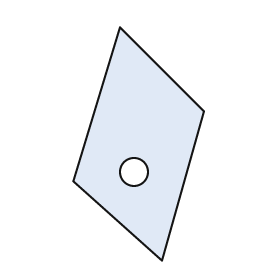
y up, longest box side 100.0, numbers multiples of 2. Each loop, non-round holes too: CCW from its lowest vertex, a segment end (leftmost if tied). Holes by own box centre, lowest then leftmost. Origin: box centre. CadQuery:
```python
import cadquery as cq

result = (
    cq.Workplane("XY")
    .moveTo(10.0, -50.0)
    .lineTo(28.0, 14.0)
    .lineTo(-8.0, 50.0)
    .lineTo(-28.0, -16.0)
    .close()
    .moveTo(-2.0, -12.0)
    .circle(6.0)
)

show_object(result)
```